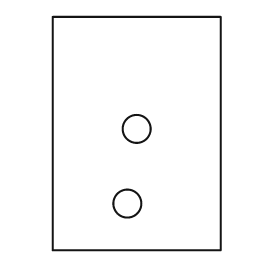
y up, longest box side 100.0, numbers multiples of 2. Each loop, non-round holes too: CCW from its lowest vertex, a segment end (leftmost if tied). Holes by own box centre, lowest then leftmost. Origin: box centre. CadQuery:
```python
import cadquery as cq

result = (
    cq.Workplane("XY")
    .moveTo(-36.0, -50.0)
    .lineTo(36.0, -50.0)
    .lineTo(36.0, 50.0)
    .lineTo(-36.0, 50.0)
    .close()
    .moveTo(-4.0, -30.0)
    .circle(6.0)
    .moveTo(0.0, 2.0)
    .circle(6.0)
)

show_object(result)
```